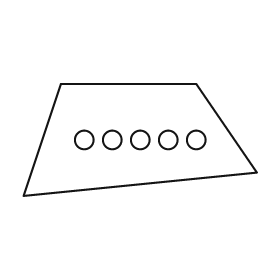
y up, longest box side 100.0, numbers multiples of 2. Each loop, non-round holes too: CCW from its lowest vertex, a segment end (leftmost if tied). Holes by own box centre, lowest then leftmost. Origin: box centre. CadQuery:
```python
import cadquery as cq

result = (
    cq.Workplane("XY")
    .moveTo(-50.0, -24.0)
    .lineTo(50.0, -14.0)
    .lineTo(24.0, 24.0)
    .lineTo(-34.0, 24.0)
    .close()
    .moveTo(-24.0, 0.0)
    .circle(4.0)
    .moveTo(-12.0, 0.0)
    .circle(4.0)
    .moveTo(0.0, 0.0)
    .circle(4.0)
    .moveTo(12.0, 0.0)
    .circle(4.0)
    .moveTo(24.0, 0.0)
    .circle(4.0)
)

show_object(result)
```